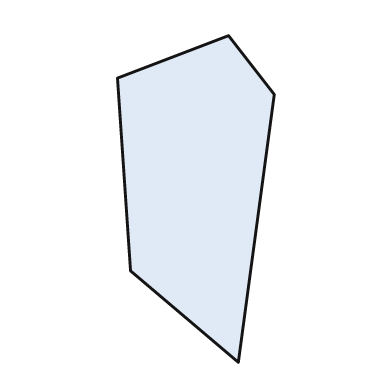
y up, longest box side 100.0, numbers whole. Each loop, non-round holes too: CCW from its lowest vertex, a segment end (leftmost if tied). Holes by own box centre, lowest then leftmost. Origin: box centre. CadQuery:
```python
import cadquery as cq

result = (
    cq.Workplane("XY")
    .moveTo(13.0, -50.0)
    .lineTo(24.0, 32.0)
    .lineTo(10.0, 50.0)
    .lineTo(-24.0, 37.0)
    .lineTo(-20.0, -22.0)
    .close()
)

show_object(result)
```